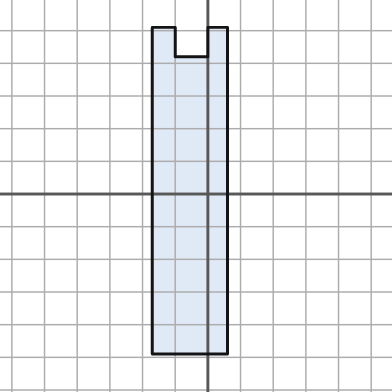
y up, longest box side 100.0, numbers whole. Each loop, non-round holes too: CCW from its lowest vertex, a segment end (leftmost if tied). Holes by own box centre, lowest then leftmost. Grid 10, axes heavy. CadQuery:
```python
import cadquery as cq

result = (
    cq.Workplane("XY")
    .moveTo(-17.0, -49.0)
    .lineTo(6.0, -49.0)
    .lineTo(6.0, 51.0)
    .lineTo(0.0, 51.0)
    .lineTo(0.0, 42.0)
    .lineTo(-10.0, 42.0)
    .lineTo(-10.0, 51.0)
    .lineTo(-17.0, 51.0)
    .close()
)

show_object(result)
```